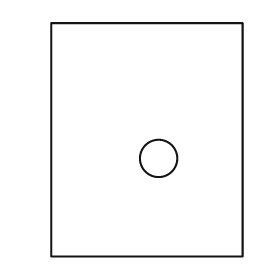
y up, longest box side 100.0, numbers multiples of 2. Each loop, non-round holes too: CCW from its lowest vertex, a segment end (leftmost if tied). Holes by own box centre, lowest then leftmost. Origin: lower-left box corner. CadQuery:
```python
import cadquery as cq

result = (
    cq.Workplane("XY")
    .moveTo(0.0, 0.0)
    .lineTo(82.0, 0.0)
    .lineTo(82.0, 100.0)
    .lineTo(0.0, 100.0)
    .close()
    .moveTo(46.0, 42.0)
    .circle(8.0)
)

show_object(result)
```